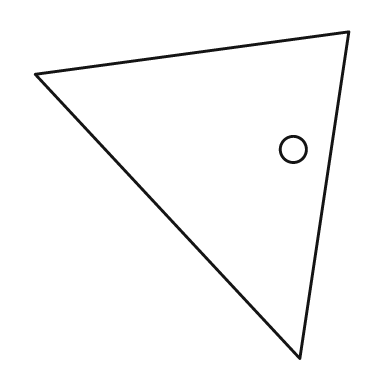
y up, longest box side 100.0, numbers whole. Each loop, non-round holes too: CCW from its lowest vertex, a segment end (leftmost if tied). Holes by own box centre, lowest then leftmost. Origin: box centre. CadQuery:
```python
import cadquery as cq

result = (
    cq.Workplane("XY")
    .moveTo(33.0, -50.0)
    .lineTo(48.0, 50.0)
    .lineTo(-48.0, 37.0)
    .close()
    .moveTo(31.0, 14.0)
    .circle(4.0)
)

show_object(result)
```